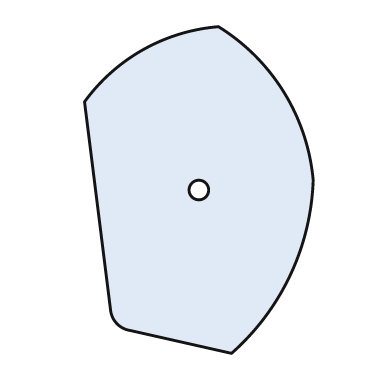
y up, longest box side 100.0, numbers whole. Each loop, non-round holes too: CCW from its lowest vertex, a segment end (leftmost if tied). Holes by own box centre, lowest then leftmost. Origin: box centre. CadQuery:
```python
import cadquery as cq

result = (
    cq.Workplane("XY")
    .moveTo(10.0, -50.0)
    .threePointArc((28.0, -26.0), (35.0, 3.0))
    .threePointArc((26.0, 30.0), (6.0, 50.0))
    .threePointArc((-17.0, 43.0), (-35.0, 27.0))
    .lineTo(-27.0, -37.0)
    .threePointArc((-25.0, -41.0), (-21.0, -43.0))
    .close()
    .moveTo(0.0, 0.0)
    .circle(3.0)
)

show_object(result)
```